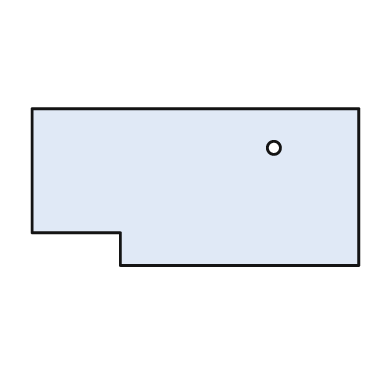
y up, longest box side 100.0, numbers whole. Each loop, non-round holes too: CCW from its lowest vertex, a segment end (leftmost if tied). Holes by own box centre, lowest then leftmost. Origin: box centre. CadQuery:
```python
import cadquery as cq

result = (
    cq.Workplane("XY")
    .moveTo(-23.0, -24.0)
    .lineTo(50.0, -24.0)
    .lineTo(50.0, 24.0)
    .lineTo(-50.0, 24.0)
    .lineTo(-50.0, -14.0)
    .lineTo(-23.0, -14.0)
    .close()
    .moveTo(24.0, 12.0)
    .circle(2.0)
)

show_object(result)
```